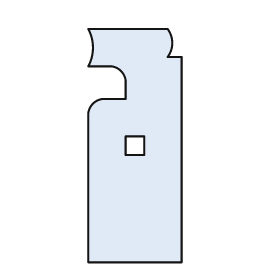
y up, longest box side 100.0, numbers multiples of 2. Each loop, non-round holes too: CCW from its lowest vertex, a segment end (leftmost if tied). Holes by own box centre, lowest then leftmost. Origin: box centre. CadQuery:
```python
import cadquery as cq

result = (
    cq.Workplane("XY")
    .moveTo(-20.0, -50.0)
    .lineTo(20.0, -50.0)
    .lineTo(20.0, 38.0)
    .lineTo(14.0, 38.0)
    .threePointArc((16.0, 44.0), (14.0, 50.0))
    .lineTo(-20.0, 50.0)
    .threePointArc((-18.0, 42.0), (-20.0, 34.0))
    .lineTo(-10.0, 34.0)
    .threePointArc((-6.0, 32.0), (-4.0, 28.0))
    .lineTo(-4.0, 20.0)
    .lineTo(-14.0, 20.0)
    .threePointArc((-18.0, 18.0), (-20.0, 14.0))
    .close()
    .moveTo(-4.0, -4.0)
    .lineTo(4.0, -4.0)
    .lineTo(4.0, 4.0)
    .lineTo(-4.0, 4.0)
    .close()
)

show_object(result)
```